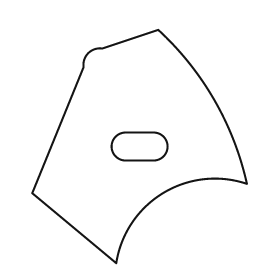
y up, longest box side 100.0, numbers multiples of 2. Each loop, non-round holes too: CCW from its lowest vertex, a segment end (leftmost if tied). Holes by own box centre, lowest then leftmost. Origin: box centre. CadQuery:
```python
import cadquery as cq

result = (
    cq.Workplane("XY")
    .moveTo(-10.0, -50.0)
    .threePointArc((10.0, -20.0), (46.0, -16.0))
    .threePointArc((32.0, 20.0), (8.0, 50.0))
    .lineTo(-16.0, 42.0)
    .threePointArc((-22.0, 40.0), (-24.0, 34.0))
    .lineTo(-46.0, -20.0)
    .close()
    .moveTo(-6.0, -6.0)
    .lineTo(6.0, -6.0)
    .threePointArc((12.0, 0.0), (6.0, 6.0))
    .lineTo(-6.0, 6.0)
    .threePointArc((-12.0, 0.0), (-6.0, -6.0))
    .close()
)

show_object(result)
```